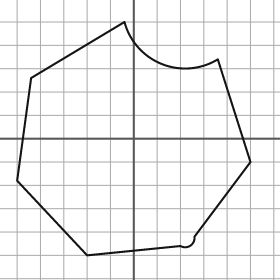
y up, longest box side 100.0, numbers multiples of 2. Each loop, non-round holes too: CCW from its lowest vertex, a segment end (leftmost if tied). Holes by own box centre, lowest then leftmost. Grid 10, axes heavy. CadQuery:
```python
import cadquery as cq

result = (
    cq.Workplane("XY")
    .moveTo(-20.0, -50.0)
    .lineTo(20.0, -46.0)
    .threePointArc((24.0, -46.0), (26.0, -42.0))
    .lineTo(50.0, -10.0)
    .lineTo(36.0, 34.0)
    .threePointArc((12.0, 32.0), (-4.0, 50.0))
    .lineTo(-44.0, 26.0)
    .lineTo(-50.0, -18.0)
    .close()
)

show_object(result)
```